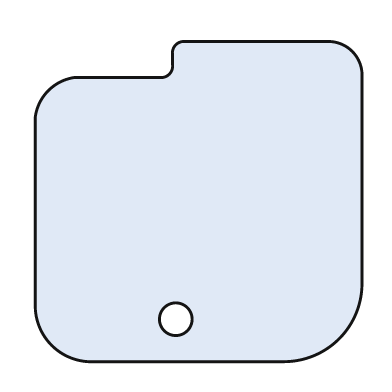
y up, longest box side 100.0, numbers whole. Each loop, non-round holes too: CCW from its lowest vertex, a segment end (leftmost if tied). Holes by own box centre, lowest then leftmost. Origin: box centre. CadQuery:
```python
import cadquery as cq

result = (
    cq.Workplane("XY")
    .moveTo(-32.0, -49.0)
    .lineTo(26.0, -49.0)
    .threePointArc((43.0, -42.0), (50.0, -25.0))
    .lineTo(50.0, 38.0)
    .threePointArc((47.0, 46.0), (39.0, 49.0))
    .lineTo(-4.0, 49.0)
    .threePointArc((-7.0, 48.0), (-8.0, 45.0))
    .lineTo(-8.0, 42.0)
    .threePointArc((-9.0, 39.0), (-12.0, 38.0))
    .lineTo(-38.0, 38.0)
    .threePointArc((-46.0, 34.0), (-50.0, 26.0))
    .lineTo(-50.0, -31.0)
    .threePointArc((-45.0, -44.0), (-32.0, -49.0))
    .close()
    .moveTo(-7.0, -36.0)
    .circle(5.0)
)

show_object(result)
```